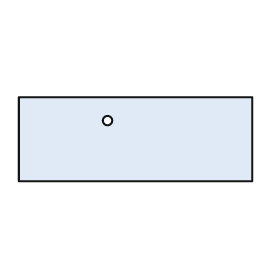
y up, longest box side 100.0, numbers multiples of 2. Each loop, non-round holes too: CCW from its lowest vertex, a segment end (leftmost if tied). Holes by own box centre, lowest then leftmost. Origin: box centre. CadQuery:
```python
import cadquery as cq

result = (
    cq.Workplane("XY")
    .moveTo(-50.0, -18.0)
    .lineTo(50.0, -18.0)
    .lineTo(50.0, 18.0)
    .lineTo(-50.0, 18.0)
    .close()
    .moveTo(-12.0, 8.0)
    .circle(2.0)
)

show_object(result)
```